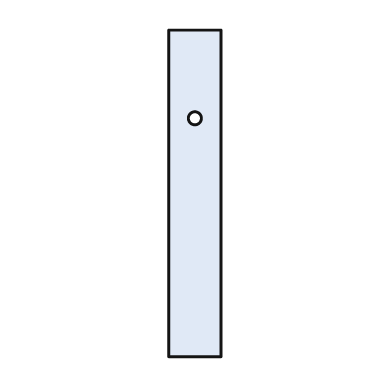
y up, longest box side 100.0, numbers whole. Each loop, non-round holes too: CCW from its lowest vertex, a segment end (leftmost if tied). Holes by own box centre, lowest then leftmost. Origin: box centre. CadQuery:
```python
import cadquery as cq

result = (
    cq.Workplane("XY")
    .moveTo(-8.0, -50.0)
    .lineTo(8.0, -50.0)
    .lineTo(8.0, 50.0)
    .lineTo(-8.0, 50.0)
    .close()
    .moveTo(0.0, 23.0)
    .circle(2.0)
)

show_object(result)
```